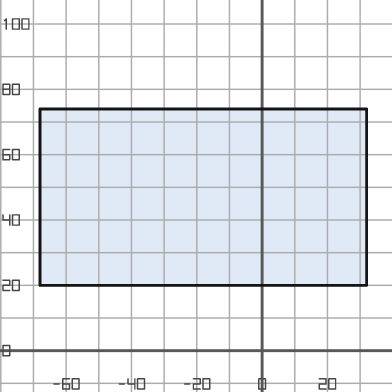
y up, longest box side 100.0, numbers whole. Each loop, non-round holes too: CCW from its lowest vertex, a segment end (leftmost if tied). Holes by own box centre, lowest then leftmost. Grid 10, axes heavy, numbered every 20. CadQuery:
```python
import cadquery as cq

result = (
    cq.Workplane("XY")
    .moveTo(-68.0, 20.0)
    .lineTo(32.0, 20.0)
    .lineTo(32.0, 74.0)
    .lineTo(-68.0, 74.0)
    .close()
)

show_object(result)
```